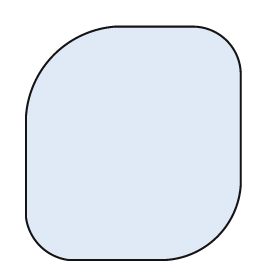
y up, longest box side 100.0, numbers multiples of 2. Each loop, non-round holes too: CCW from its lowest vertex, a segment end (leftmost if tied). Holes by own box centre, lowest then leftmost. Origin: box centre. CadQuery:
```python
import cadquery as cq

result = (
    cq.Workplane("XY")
    .moveTo(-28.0, -50.0)
    .lineTo(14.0, -50.0)
    .threePointArc((36.0, -40.0), (46.0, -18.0))
    .lineTo(46.0, 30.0)
    .threePointArc((40.0, 44.0), (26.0, 50.0))
    .lineTo(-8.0, 50.0)
    .threePointArc((-34.0, 38.0), (-46.0, 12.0))
    .lineTo(-46.0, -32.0)
    .threePointArc((-40.0, -44.0), (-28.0, -50.0))
    .close()
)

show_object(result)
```